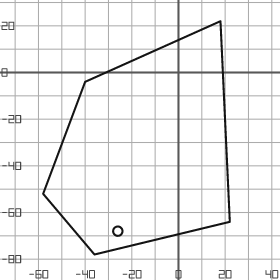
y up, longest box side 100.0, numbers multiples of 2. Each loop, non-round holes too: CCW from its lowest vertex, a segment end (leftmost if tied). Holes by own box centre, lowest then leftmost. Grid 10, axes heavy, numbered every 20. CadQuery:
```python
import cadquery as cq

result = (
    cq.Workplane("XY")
    .moveTo(-36.0, -78.0)
    .lineTo(22.0, -64.0)
    .lineTo(18.0, 22.0)
    .lineTo(-40.0, -4.0)
    .lineTo(-58.0, -52.0)
    .close()
    .moveTo(-26.0, -68.0)
    .circle(2.0)
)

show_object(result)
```